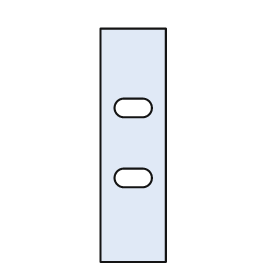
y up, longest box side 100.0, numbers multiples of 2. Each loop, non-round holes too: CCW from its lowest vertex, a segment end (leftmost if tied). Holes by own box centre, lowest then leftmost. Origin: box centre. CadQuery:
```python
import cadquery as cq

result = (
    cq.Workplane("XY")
    .moveTo(-14.0, -50.0)
    .lineTo(14.0, -50.0)
    .lineTo(14.0, 50.0)
    .lineTo(-14.0, 50.0)
    .close()
    .moveTo(-4.0, -18.0)
    .lineTo(4.0, -18.0)
    .threePointArc((8.0, -14.0), (4.0, -10.0))
    .lineTo(-4.0, -10.0)
    .threePointArc((-8.0, -14.0), (-4.0, -18.0))
    .close()
    .moveTo(-4.0, 12.0)
    .lineTo(4.0, 12.0)
    .threePointArc((8.0, 16.0), (4.0, 20.0))
    .lineTo(-4.0, 20.0)
    .threePointArc((-8.0, 16.0), (-4.0, 12.0))
    .close()
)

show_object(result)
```